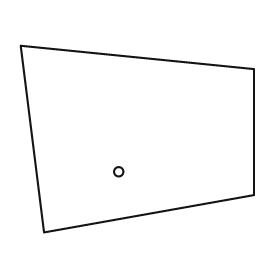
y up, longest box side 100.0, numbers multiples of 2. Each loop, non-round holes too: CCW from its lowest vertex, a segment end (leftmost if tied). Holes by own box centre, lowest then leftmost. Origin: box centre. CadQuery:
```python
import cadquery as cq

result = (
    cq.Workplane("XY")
    .moveTo(-40.0, -40.0)
    .lineTo(50.0, -24.0)
    .lineTo(50.0, 30.0)
    .lineTo(-50.0, 40.0)
    .close()
    .moveTo(-8.0, -14.0)
    .circle(2.0)
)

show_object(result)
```